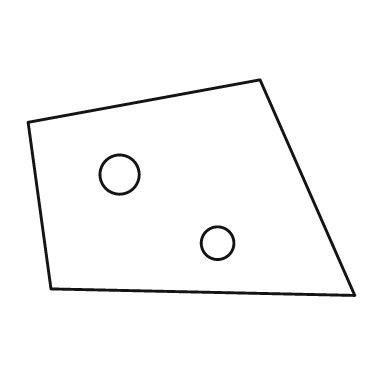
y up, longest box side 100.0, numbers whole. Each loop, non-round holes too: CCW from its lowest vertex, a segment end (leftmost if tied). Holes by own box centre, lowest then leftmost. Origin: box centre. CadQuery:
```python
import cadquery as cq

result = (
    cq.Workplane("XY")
    .moveTo(50.0, -33.0)
    .lineTo(21.0, 33.0)
    .lineTo(-50.0, 20.0)
    .lineTo(-43.0, -31.0)
    .close()
    .moveTo(8.0, -17.0)
    .circle(5.0)
    .moveTo(-22.0, 4.0)
    .circle(6.0)
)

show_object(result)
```